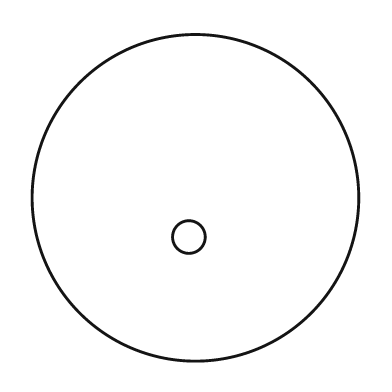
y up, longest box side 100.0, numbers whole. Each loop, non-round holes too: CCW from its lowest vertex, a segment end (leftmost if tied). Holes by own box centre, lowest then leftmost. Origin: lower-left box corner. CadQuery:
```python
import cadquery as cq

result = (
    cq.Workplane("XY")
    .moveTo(50.0, 50.0)
    .circle(50.0)
    .moveTo(48.0, 38.0)
    .circle(5.0)
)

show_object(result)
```